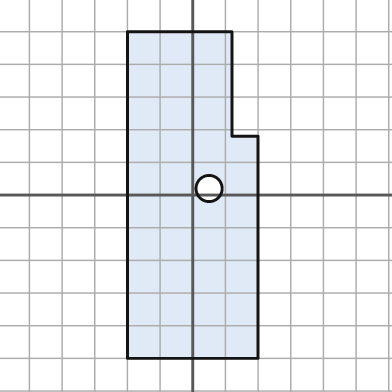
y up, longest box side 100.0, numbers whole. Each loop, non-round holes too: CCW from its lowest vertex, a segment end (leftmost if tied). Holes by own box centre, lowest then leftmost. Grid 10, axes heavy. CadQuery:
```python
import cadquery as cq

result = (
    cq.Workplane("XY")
    .moveTo(-20.0, -50.0)
    .lineTo(20.0, -50.0)
    .lineTo(20.0, 18.0)
    .lineTo(12.0, 18.0)
    .lineTo(12.0, 50.0)
    .lineTo(-20.0, 50.0)
    .close()
    .moveTo(5.0, 2.0)
    .circle(4.0)
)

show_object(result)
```